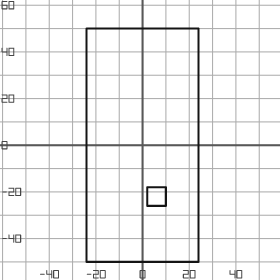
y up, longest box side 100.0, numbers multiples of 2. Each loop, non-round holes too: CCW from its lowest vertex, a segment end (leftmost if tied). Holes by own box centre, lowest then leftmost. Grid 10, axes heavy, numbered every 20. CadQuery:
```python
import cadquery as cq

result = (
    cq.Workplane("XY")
    .moveTo(-24.0, -50.0)
    .lineTo(24.0, -50.0)
    .lineTo(24.0, 50.0)
    .lineTo(-24.0, 50.0)
    .close()
    .moveTo(2.0, -26.0)
    .lineTo(10.0, -26.0)
    .lineTo(10.0, -18.0)
    .lineTo(2.0, -18.0)
    .close()
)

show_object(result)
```